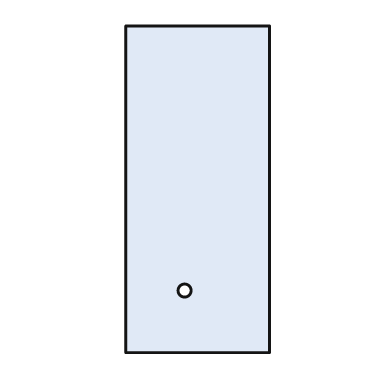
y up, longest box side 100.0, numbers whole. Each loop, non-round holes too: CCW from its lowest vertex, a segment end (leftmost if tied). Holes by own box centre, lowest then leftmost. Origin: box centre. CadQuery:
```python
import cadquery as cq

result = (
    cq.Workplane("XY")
    .moveTo(-22.0, -50.0)
    .lineTo(22.0, -50.0)
    .lineTo(22.0, 50.0)
    .lineTo(-22.0, 50.0)
    .close()
    .moveTo(-4.0, -31.0)
    .circle(2.0)
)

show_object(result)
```